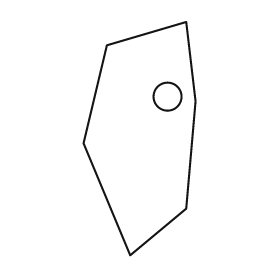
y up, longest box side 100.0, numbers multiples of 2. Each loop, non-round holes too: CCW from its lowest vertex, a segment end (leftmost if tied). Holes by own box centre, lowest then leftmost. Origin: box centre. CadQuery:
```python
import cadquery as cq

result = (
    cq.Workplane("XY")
    .moveTo(-4.0, -50.0)
    .lineTo(20.0, -30.0)
    .lineTo(24.0, 16.0)
    .lineTo(20.0, 50.0)
    .lineTo(-14.0, 40.0)
    .lineTo(-24.0, -2.0)
    .close()
    .moveTo(12.0, 18.0)
    .circle(6.0)
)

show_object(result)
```